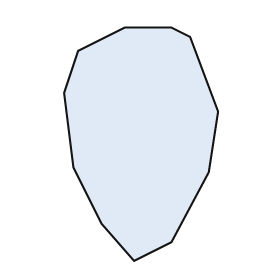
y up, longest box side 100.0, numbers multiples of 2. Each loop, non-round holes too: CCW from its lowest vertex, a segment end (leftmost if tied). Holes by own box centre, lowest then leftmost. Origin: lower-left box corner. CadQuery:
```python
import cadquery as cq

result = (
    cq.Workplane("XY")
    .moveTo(30.0, 0.0)
    .lineTo(46.0, 8.0)
    .lineTo(62.0, 38.0)
    .lineTo(66.0, 64.0)
    .lineTo(54.0, 96.0)
    .lineTo(46.0, 100.0)
    .lineTo(26.0, 100.0)
    .lineTo(6.0, 90.0)
    .lineTo(0.0, 72.0)
    .lineTo(4.0, 40.0)
    .lineTo(16.0, 16.0)
    .close()
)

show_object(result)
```